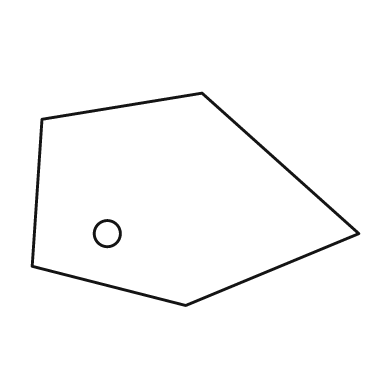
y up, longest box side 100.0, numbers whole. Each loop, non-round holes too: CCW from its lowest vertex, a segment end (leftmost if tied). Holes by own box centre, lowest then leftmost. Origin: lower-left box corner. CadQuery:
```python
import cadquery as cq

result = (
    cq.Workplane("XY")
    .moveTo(47.0, 0.0)
    .lineTo(100.0, 22.0)
    .lineTo(52.0, 65.0)
    .lineTo(3.0, 57.0)
    .lineTo(0.0, 12.0)
    .close()
    .moveTo(23.0, 22.0)
    .circle(4.0)
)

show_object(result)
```